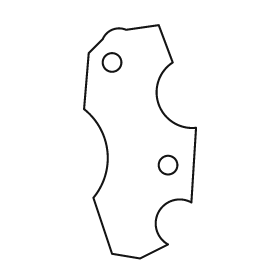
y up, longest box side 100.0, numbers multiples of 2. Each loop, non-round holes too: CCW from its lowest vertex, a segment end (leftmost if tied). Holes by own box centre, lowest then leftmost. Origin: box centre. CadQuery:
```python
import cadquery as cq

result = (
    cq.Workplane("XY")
    .moveTo(0.0, -50.0)
    .lineTo(12.0, -44.0)
    .threePointArc((8.0, -30.0), (22.0, -26.0))
    .lineTo(24.0, 6.0)
    .threePointArc((8.0, 16.0), (14.0, 34.0))
    .lineTo(8.0, 50.0)
    .lineTo(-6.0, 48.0)
    .threePointArc((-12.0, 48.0), (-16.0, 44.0))
    .lineTo(-22.0, 38.0)
    .lineTo(-24.0, 14.0)
    .threePointArc((-14.0, -4.0), (-20.0, -24.0))
    .lineTo(-12.0, -48.0)
    .close()
    .moveTo(12.0, -10.0)
    .circle(4.0)
    .moveTo(-12.0, 34.0)
    .circle(4.0)
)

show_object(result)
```